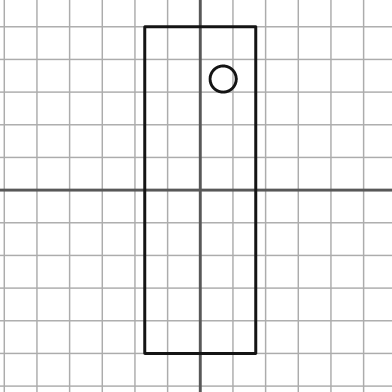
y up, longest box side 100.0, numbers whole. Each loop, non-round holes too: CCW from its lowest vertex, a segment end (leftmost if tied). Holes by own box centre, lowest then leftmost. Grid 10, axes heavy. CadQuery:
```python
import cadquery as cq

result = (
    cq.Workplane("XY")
    .moveTo(-17.0, -50.0)
    .lineTo(17.0, -50.0)
    .lineTo(17.0, 50.0)
    .lineTo(-17.0, 50.0)
    .close()
    .moveTo(7.0, 34.0)
    .circle(4.0)
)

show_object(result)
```